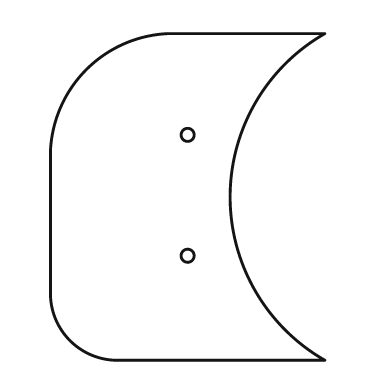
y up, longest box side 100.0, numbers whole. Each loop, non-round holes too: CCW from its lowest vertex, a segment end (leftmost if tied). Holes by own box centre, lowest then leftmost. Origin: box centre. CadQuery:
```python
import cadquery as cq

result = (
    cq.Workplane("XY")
    .moveTo(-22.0, -50.0)
    .lineTo(42.0, -50.0)
    .threePointArc((13.0, 0.0), (42.0, 50.0))
    .lineTo(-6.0, 50.0)
    .threePointArc((-31.0, 39.0), (-42.0, 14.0))
    .lineTo(-42.0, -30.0)
    .threePointArc((-36.0, -44.0), (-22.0, -50.0))
    .close()
    .moveTo(0.0, -18.0)
    .circle(2.0)
    .moveTo(0.0, 19.0)
    .circle(2.0)
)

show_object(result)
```